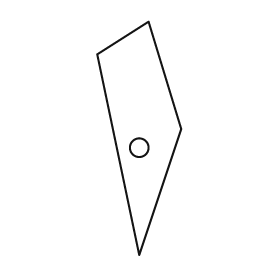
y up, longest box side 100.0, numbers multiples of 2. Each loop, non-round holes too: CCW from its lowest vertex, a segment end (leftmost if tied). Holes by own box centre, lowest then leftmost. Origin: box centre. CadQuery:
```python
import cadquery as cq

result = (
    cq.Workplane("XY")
    .moveTo(0.0, -50.0)
    .lineTo(18.0, 4.0)
    .lineTo(4.0, 50.0)
    .lineTo(-18.0, 36.0)
    .close()
    .moveTo(0.0, -4.0)
    .circle(4.0)
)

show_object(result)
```